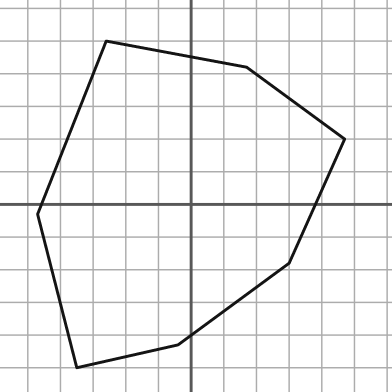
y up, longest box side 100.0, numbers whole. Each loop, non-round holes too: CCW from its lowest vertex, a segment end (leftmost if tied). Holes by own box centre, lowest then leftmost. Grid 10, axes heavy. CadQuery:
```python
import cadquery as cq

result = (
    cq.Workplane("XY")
    .moveTo(-35.0, -50.0)
    .lineTo(-4.0, -43.0)
    .lineTo(30.0, -18.0)
    .lineTo(47.0, 20.0)
    .lineTo(17.0, 42.0)
    .lineTo(-26.0, 50.0)
    .lineTo(-47.0, -3.0)
    .close()
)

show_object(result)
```